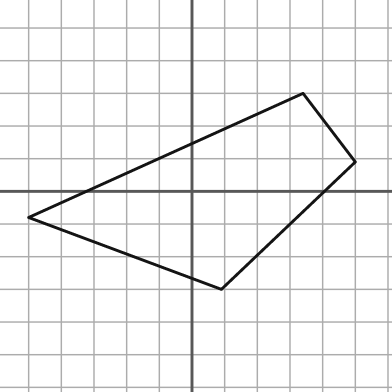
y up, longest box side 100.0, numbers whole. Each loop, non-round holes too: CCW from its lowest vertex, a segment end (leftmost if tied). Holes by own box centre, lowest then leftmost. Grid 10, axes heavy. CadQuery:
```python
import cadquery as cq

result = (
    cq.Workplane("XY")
    .moveTo(9.0, -30.0)
    .lineTo(50.0, 9.0)
    .lineTo(34.0, 30.0)
    .lineTo(-50.0, -8.0)
    .close()
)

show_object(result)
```